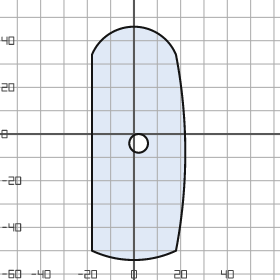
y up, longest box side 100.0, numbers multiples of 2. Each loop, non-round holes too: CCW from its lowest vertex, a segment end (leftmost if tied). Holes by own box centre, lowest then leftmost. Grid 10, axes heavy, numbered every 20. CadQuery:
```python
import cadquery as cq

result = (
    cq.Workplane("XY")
    .moveTo(-18.0, -50.0)
    .threePointArc((0.0, -54.0), (18.0, -50.0))
    .threePointArc((22.0, -8.0), (18.0, 34.0))
    .threePointArc((0.0, 46.0), (-18.0, 34.0))
    .close()
    .moveTo(2.0, -4.0)
    .circle(4.0)
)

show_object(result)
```